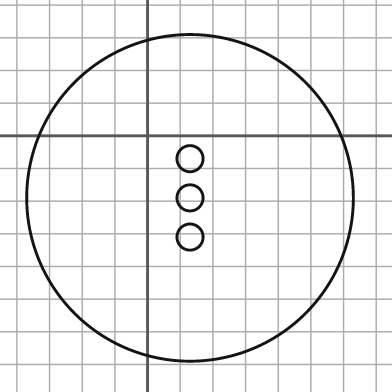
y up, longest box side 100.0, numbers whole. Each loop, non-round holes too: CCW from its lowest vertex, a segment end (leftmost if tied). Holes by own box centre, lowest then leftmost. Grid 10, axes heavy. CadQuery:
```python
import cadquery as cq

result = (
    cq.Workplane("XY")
    .moveTo(13.0, -19.0)
    .circle(50.0)
    .moveTo(13.0, -31.0)
    .circle(4.0)
    .moveTo(13.0, -19.0)
    .circle(4.0)
    .moveTo(13.0, -7.0)
    .circle(4.0)
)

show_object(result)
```